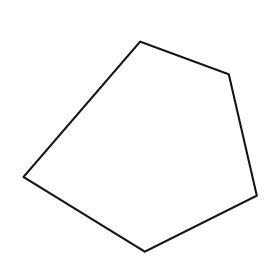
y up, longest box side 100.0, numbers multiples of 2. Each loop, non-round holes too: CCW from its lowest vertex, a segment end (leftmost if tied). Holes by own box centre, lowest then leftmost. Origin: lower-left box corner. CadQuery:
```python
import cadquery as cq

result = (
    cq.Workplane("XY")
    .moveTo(52.0, 0.0)
    .lineTo(100.0, 24.0)
    .lineTo(88.0, 76.0)
    .lineTo(50.0, 90.0)
    .lineTo(0.0, 32.0)
    .close()
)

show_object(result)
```